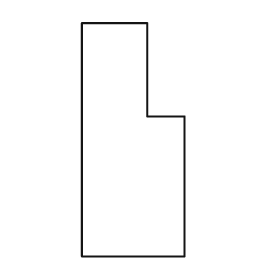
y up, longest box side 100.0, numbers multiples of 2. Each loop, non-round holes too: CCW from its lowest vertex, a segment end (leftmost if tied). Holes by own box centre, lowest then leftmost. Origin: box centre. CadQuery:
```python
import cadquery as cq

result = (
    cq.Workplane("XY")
    .moveTo(-22.0, -50.0)
    .lineTo(22.0, -50.0)
    .lineTo(22.0, 10.0)
    .lineTo(6.0, 10.0)
    .lineTo(6.0, 50.0)
    .lineTo(-22.0, 50.0)
    .close()
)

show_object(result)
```